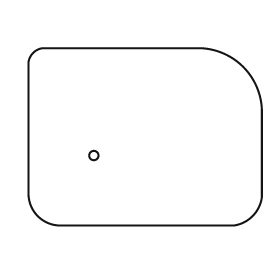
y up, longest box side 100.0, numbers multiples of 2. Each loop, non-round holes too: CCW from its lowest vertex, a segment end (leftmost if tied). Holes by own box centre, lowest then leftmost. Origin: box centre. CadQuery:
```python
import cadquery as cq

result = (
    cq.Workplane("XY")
    .moveTo(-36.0, -38.0)
    .lineTo(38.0, -38.0)
    .threePointArc((46.0, -34.0), (50.0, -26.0))
    .lineTo(50.0, 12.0)
    .threePointArc((42.0, 30.0), (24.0, 38.0))
    .lineTo(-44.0, 38.0)
    .threePointArc((-48.0, 36.0), (-50.0, 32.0))
    .lineTo(-50.0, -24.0)
    .threePointArc((-46.0, -34.0), (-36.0, -38.0))
    .close()
    .moveTo(-22.0, -8.0)
    .circle(2.0)
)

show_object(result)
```